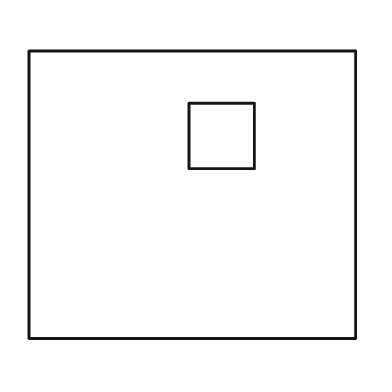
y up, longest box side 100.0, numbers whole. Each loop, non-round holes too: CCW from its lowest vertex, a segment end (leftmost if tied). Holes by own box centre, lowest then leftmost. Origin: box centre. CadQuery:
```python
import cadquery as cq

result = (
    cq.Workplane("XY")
    .moveTo(-50.0, -44.0)
    .lineTo(50.0, -44.0)
    .lineTo(50.0, 44.0)
    .lineTo(-50.0, 44.0)
    .close()
    .moveTo(-1.0, 8.0)
    .lineTo(19.0, 8.0)
    .lineTo(19.0, 28.0)
    .lineTo(-1.0, 28.0)
    .close()
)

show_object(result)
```